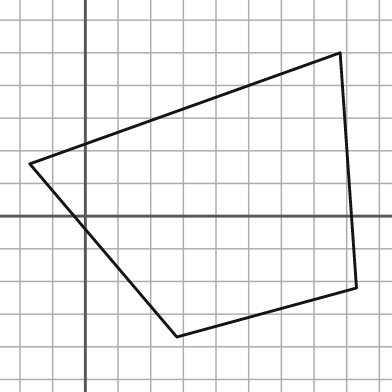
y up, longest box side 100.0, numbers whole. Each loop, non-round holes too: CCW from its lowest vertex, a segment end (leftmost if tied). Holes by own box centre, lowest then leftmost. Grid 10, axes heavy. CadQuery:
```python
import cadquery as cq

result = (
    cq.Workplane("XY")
    .moveTo(28.0, -37.0)
    .lineTo(83.0, -22.0)
    .lineTo(78.0, 50.0)
    .lineTo(-17.0, 16.0)
    .close()
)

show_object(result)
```